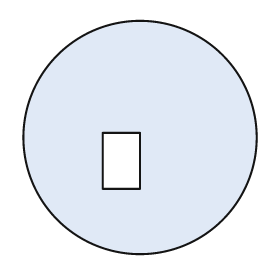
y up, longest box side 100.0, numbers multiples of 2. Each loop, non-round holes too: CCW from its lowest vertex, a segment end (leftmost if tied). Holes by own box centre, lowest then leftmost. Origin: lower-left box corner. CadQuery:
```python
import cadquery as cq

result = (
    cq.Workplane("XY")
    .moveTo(50.0, 50.0)
    .circle(50.0)
    .moveTo(34.0, 28.0)
    .lineTo(50.0, 28.0)
    .lineTo(50.0, 52.0)
    .lineTo(34.0, 52.0)
    .close()
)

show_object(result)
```